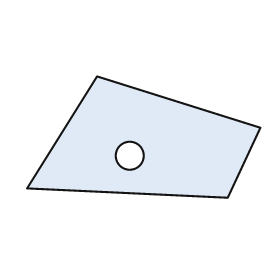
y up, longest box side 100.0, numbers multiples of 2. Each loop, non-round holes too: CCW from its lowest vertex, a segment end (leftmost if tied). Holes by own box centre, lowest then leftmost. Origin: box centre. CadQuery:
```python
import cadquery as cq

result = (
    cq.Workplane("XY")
    .moveTo(36.0, -26.0)
    .lineTo(50.0, 4.0)
    .lineTo(-20.0, 26.0)
    .lineTo(-50.0, -22.0)
    .close()
    .moveTo(-6.0, -8.0)
    .circle(6.0)
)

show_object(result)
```